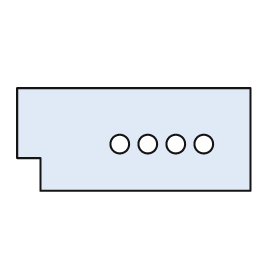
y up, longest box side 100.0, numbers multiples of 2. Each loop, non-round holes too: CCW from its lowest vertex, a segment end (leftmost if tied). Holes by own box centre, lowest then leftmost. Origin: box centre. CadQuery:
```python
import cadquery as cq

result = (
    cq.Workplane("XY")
    .moveTo(-40.0, -22.0)
    .lineTo(50.0, -22.0)
    .lineTo(50.0, 22.0)
    .lineTo(-50.0, 22.0)
    .lineTo(-50.0, -8.0)
    .lineTo(-40.0, -8.0)
    .close()
    .moveTo(-6.0, -2.0)
    .circle(4.0)
    .moveTo(6.0, -2.0)
    .circle(4.0)
    .moveTo(18.0, -2.0)
    .circle(4.0)
    .moveTo(30.0, -2.0)
    .circle(4.0)
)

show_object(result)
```